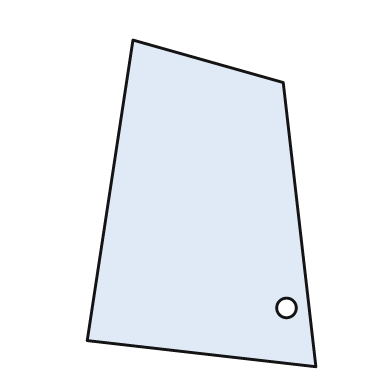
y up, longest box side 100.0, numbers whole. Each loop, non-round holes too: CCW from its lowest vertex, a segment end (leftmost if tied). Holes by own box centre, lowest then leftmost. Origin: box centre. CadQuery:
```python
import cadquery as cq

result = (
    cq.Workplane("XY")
    .moveTo(35.0, -50.0)
    .lineTo(25.0, 37.0)
    .lineTo(-21.0, 50.0)
    .lineTo(-35.0, -42.0)
    .close()
    .moveTo(26.0, -32.0)
    .circle(3.0)
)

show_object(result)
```